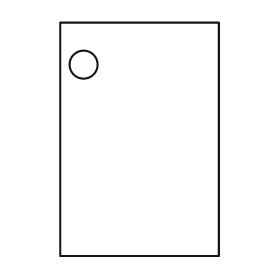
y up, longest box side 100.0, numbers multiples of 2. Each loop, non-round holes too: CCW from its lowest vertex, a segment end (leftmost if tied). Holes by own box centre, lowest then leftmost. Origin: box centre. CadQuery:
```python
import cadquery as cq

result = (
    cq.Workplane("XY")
    .moveTo(-34.0, -50.0)
    .lineTo(34.0, -50.0)
    .lineTo(34.0, 50.0)
    .lineTo(-34.0, 50.0)
    .close()
    .moveTo(-24.0, 32.0)
    .circle(6.0)
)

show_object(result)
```